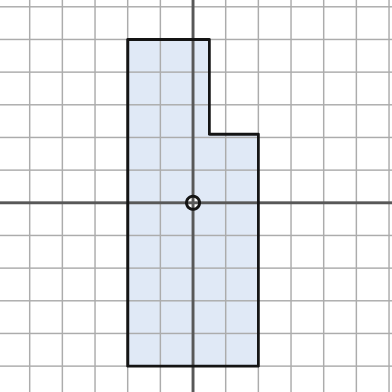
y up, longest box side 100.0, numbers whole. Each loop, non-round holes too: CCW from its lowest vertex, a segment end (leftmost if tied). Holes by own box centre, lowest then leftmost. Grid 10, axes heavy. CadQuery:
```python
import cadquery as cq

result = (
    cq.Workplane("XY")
    .moveTo(-20.0, -50.0)
    .lineTo(20.0, -50.0)
    .lineTo(20.0, 21.0)
    .lineTo(5.0, 21.0)
    .lineTo(5.0, 50.0)
    .lineTo(-20.0, 50.0)
    .close()
    .moveTo(0.0, 0.0)
    .circle(2.0)
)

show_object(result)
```